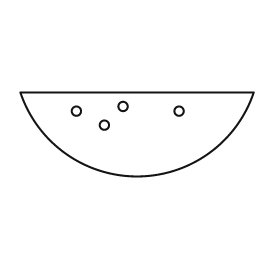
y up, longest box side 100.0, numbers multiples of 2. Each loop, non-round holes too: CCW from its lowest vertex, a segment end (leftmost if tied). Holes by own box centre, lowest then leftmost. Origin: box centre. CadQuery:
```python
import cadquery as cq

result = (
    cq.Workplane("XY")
    .moveTo(-50.0, 18.0)
    .threePointArc((0.0, -18.0), (50.0, 18.0))
    .close()
    .moveTo(-14.0, 4.0)
    .circle(2.0)
    .moveTo(-26.0, 10.0)
    .circle(2.0)
    .moveTo(18.0, 10.0)
    .circle(2.0)
    .moveTo(-6.0, 12.0)
    .circle(2.0)
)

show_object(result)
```